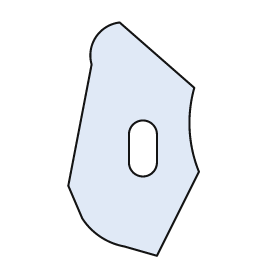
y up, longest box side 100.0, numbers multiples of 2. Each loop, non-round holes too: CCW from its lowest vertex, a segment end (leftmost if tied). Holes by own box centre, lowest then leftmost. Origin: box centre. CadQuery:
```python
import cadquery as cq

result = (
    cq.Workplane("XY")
    .moveTo(10.0, -50.0)
    .lineTo(28.0, -14.0)
    .threePointArc((24.0, 4.0), (26.0, 22.0))
    .lineTo(-6.0, 50.0)
    .threePointArc((-16.0, 44.0), (-18.0, 32.0))
    .lineTo(-28.0, -20.0)
    .lineTo(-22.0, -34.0)
    .threePointArc((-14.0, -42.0), (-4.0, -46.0))
    .close()
    .moveTo(-2.0, -10.0)
    .threePointArc((4.0, -16.0), (10.0, -10.0))
    .lineTo(10.0, 2.0)
    .threePointArc((4.0, 8.0), (-2.0, 2.0))
    .close()
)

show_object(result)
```